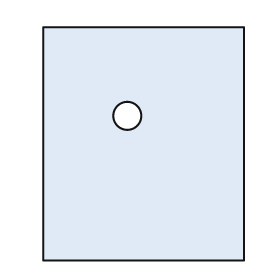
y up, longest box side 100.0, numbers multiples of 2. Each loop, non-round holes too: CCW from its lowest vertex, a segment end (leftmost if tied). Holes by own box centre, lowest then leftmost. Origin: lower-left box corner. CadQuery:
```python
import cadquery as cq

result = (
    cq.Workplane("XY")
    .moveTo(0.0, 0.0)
    .lineTo(86.0, 0.0)
    .lineTo(86.0, 100.0)
    .lineTo(0.0, 100.0)
    .close()
    .moveTo(36.0, 62.0)
    .circle(6.0)
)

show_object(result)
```